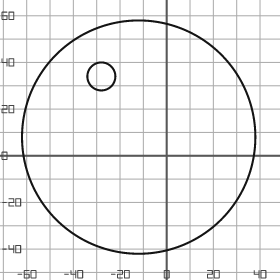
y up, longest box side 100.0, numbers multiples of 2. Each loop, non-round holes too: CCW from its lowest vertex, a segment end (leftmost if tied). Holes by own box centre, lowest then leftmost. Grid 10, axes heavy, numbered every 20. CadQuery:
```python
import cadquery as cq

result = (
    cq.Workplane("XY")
    .moveTo(-12.0, 8.0)
    .circle(50.0)
    .moveTo(-28.0, 34.0)
    .circle(6.0)
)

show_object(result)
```